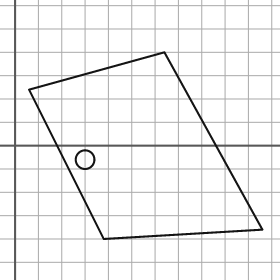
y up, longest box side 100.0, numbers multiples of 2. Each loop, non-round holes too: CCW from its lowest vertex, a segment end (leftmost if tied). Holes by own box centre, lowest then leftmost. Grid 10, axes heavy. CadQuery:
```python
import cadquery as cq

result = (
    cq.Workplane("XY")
    .moveTo(38.0, -40.0)
    .lineTo(106.0, -36.0)
    .lineTo(64.0, 40.0)
    .lineTo(6.0, 24.0)
    .close()
    .moveTo(30.0, -6.0)
    .circle(4.0)
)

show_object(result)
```